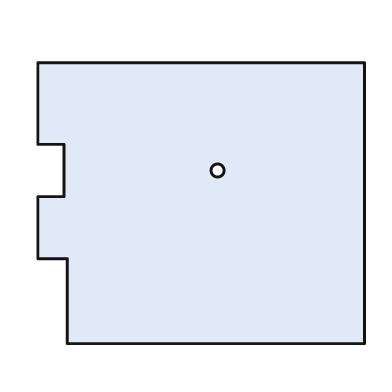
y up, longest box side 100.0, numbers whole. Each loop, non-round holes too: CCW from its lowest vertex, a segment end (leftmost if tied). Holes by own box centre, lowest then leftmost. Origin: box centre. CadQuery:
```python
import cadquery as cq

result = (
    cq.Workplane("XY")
    .moveTo(-41.0, -43.0)
    .lineTo(50.0, -43.0)
    .lineTo(50.0, 43.0)
    .lineTo(-50.0, 43.0)
    .lineTo(-50.0, 18.0)
    .lineTo(-42.0, 18.0)
    .lineTo(-42.0, 2.0)
    .lineTo(-50.0, 2.0)
    .lineTo(-50.0, -17.0)
    .lineTo(-41.0, -17.0)
    .close()
    .moveTo(5.0, 10.0)
    .circle(2.0)
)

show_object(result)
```